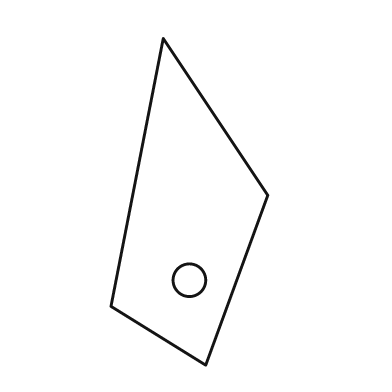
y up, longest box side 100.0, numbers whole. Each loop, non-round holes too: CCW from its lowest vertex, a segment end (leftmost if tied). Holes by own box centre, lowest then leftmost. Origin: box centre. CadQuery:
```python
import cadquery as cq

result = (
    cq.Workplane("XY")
    .moveTo(5.0, -50.0)
    .lineTo(24.0, 2.0)
    .lineTo(-8.0, 50.0)
    .lineTo(-24.0, -32.0)
    .close()
    .moveTo(0.0, -24.0)
    .circle(5.0)
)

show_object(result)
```